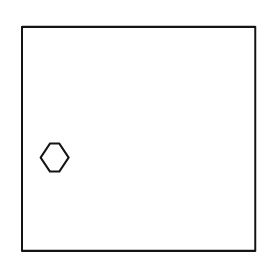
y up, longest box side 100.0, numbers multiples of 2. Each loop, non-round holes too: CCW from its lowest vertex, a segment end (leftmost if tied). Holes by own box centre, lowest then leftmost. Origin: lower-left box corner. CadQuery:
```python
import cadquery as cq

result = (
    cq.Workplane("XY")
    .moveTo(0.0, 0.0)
    .lineTo(100.0, 0.0)
    .lineTo(100.0, 96.0)
    .lineTo(0.0, 96.0)
    .close()
    .moveTo(12.0, 34.0)
    .lineTo(16.0, 34.0)
    .lineTo(20.0, 40.0)
    .lineTo(16.0, 46.0)
    .lineTo(12.0, 46.0)
    .lineTo(8.0, 40.0)
    .close()
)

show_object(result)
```